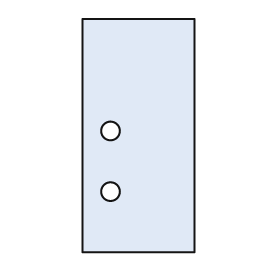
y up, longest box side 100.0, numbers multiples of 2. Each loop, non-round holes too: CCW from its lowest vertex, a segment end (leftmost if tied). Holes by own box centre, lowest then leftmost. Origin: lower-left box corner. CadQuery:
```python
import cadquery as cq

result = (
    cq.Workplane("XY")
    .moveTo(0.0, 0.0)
    .lineTo(48.0, 0.0)
    .lineTo(48.0, 100.0)
    .lineTo(0.0, 100.0)
    .close()
    .moveTo(12.0, 26.0)
    .circle(4.0)
    .moveTo(12.0, 52.0)
    .circle(4.0)
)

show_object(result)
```